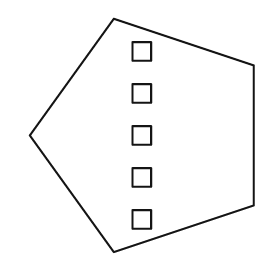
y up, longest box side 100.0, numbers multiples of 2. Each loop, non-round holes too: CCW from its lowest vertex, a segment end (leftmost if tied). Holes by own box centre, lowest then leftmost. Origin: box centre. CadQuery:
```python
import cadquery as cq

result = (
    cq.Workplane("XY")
    .moveTo(-12.0, -50.0)
    .lineTo(48.0, -30.0)
    .lineTo(48.0, 30.0)
    .lineTo(-12.0, 50.0)
    .lineTo(-48.0, 0.0)
    .close()
    .moveTo(-4.0, -40.0)
    .lineTo(4.0, -40.0)
    .lineTo(4.0, -32.0)
    .lineTo(-4.0, -32.0)
    .close()
    .moveTo(-4.0, -22.0)
    .lineTo(4.0, -22.0)
    .lineTo(4.0, -14.0)
    .lineTo(-4.0, -14.0)
    .close()
    .moveTo(-4.0, -4.0)
    .lineTo(4.0, -4.0)
    .lineTo(4.0, 4.0)
    .lineTo(-4.0, 4.0)
    .close()
    .moveTo(-4.0, 14.0)
    .lineTo(4.0, 14.0)
    .lineTo(4.0, 22.0)
    .lineTo(-4.0, 22.0)
    .close()
    .moveTo(-4.0, 32.0)
    .lineTo(4.0, 32.0)
    .lineTo(4.0, 40.0)
    .lineTo(-4.0, 40.0)
    .close()
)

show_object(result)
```